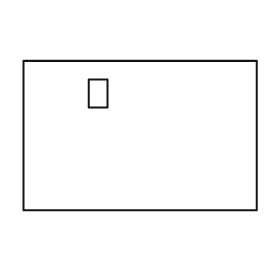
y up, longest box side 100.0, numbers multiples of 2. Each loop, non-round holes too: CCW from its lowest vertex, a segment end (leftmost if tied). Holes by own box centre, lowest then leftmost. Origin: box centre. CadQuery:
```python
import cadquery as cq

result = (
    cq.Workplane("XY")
    .moveTo(-50.0, -32.0)
    .lineTo(50.0, -32.0)
    .lineTo(50.0, 32.0)
    .lineTo(-50.0, 32.0)
    .close()
    .moveTo(-22.0, 12.0)
    .lineTo(-14.0, 12.0)
    .lineTo(-14.0, 24.0)
    .lineTo(-22.0, 24.0)
    .close()
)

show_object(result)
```